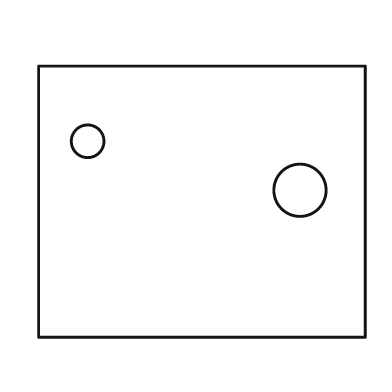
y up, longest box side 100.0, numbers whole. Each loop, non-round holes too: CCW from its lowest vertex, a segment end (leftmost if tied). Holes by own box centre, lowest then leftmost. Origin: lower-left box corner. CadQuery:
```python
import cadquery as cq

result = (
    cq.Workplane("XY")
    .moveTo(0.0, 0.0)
    .lineTo(100.0, 0.0)
    .lineTo(100.0, 83.0)
    .lineTo(0.0, 83.0)
    .close()
    .moveTo(80.0, 45.0)
    .circle(8.0)
    .moveTo(15.0, 60.0)
    .circle(5.0)
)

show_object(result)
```